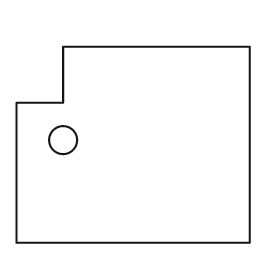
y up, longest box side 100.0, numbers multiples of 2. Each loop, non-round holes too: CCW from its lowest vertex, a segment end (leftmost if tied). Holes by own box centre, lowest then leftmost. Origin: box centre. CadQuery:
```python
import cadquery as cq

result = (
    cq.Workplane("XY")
    .moveTo(-50.0, -42.0)
    .lineTo(50.0, -42.0)
    .lineTo(50.0, 42.0)
    .lineTo(-30.0, 42.0)
    .lineTo(-30.0, 18.0)
    .lineTo(-50.0, 18.0)
    .close()
    .moveTo(-30.0, 2.0)
    .circle(6.0)
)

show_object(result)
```